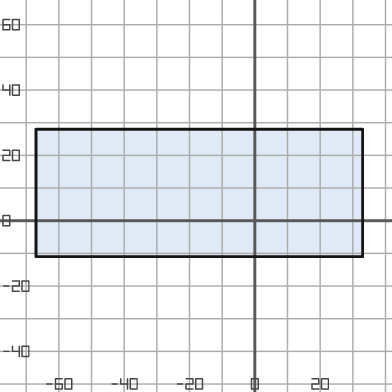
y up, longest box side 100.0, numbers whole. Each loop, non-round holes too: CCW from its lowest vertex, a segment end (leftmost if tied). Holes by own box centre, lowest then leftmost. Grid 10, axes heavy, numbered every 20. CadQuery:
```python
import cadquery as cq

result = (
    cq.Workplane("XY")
    .moveTo(-67.0, -11.0)
    .lineTo(33.0, -11.0)
    .lineTo(33.0, 28.0)
    .lineTo(-67.0, 28.0)
    .close()
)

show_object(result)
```